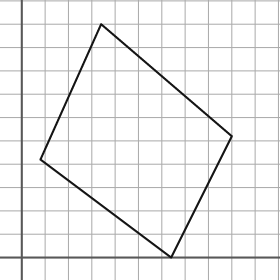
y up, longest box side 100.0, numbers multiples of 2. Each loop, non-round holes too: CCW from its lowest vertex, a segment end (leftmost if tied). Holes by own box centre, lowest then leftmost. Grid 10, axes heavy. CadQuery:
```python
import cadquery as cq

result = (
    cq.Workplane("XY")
    .moveTo(64.0, 0.0)
    .lineTo(90.0, 52.0)
    .lineTo(34.0, 100.0)
    .lineTo(8.0, 42.0)
    .close()
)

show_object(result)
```